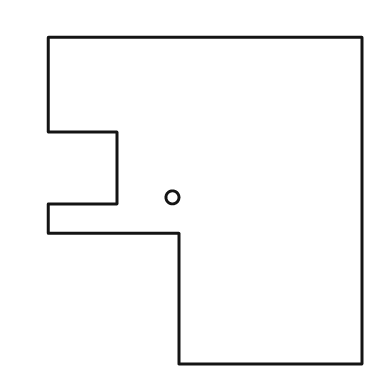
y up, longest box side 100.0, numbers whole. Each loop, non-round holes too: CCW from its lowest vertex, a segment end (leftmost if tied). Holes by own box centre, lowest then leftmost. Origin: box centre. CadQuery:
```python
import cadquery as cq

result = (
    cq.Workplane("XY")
    .moveTo(-8.0, -50.0)
    .lineTo(48.0, -50.0)
    .lineTo(48.0, 50.0)
    .lineTo(-48.0, 50.0)
    .lineTo(-48.0, 21.0)
    .lineTo(-27.0, 21.0)
    .lineTo(-27.0, -1.0)
    .lineTo(-48.0, -1.0)
    .lineTo(-48.0, -10.0)
    .lineTo(-8.0, -10.0)
    .close()
    .moveTo(-10.0, 1.0)
    .circle(2.0)
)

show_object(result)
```